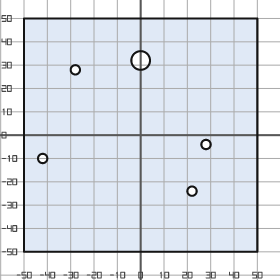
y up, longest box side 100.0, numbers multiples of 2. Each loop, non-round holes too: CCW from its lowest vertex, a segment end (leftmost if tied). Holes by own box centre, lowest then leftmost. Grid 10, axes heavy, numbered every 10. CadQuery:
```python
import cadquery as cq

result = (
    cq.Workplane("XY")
    .moveTo(-50.0, -50.0)
    .lineTo(50.0, -50.0)
    .lineTo(50.0, 50.0)
    .lineTo(-50.0, 50.0)
    .close()
    .moveTo(22.0, -24.0)
    .circle(2.0)
    .moveTo(-42.0, -10.0)
    .circle(2.0)
    .moveTo(28.0, -4.0)
    .circle(2.0)
    .moveTo(-28.0, 28.0)
    .circle(2.0)
    .moveTo(0.0, 32.0)
    .circle(4.0)
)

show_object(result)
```